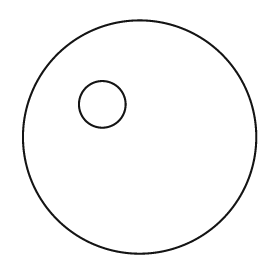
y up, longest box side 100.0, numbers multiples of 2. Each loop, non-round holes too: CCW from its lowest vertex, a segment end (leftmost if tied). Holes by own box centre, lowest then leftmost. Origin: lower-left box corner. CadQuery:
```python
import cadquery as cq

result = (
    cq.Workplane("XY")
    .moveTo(50.0, 50.0)
    .circle(50.0)
    .moveTo(34.0, 64.0)
    .circle(10.0)
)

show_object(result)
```